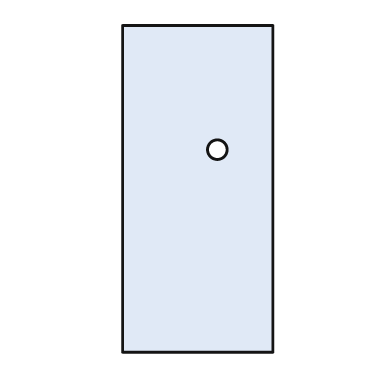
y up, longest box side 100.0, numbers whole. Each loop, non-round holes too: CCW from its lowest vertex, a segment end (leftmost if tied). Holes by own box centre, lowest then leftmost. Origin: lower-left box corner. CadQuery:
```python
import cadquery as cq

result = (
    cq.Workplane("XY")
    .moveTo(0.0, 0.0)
    .lineTo(46.0, 0.0)
    .lineTo(46.0, 100.0)
    .lineTo(0.0, 100.0)
    .close()
    .moveTo(29.0, 62.0)
    .circle(3.0)
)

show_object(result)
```